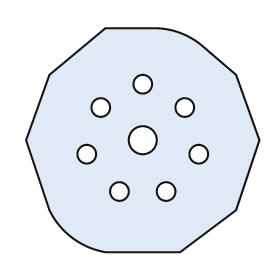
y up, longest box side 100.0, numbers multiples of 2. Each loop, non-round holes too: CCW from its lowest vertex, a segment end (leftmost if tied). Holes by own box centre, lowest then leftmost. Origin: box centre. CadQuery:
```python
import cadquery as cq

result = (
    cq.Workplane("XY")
    .moveTo(-16.0, -48.0)
    .lineTo(16.0, -48.0)
    .lineTo(40.0, -30.0)
    .lineTo(50.0, 0.0)
    .lineTo(40.0, 28.0)
    .lineTo(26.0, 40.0)
    .threePointArc((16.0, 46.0), (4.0, 48.0))
    .lineTo(-16.0, 48.0)
    .lineTo(-40.0, 28.0)
    .lineTo(-50.0, 0.0)
    .lineTo(-40.0, -30.0)
    .threePointArc((-30.0, -42.0), (-16.0, -48.0))
    .close()
    .moveTo(-10.0, -22.0)
    .circle(4.0)
    .moveTo(10.0, -22.0)
    .circle(4.0)
    .moveTo(-24.0, -6.0)
    .circle(4.0)
    .moveTo(24.0, -6.0)
    .circle(4.0)
    .moveTo(0.0, 0.0)
    .circle(6.0)
    .moveTo(-18.0, 14.0)
    .circle(4.0)
    .moveTo(18.0, 14.0)
    .circle(4.0)
    .moveTo(0.0, 24.0)
    .circle(4.0)
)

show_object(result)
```